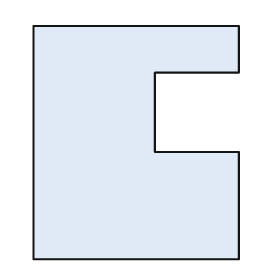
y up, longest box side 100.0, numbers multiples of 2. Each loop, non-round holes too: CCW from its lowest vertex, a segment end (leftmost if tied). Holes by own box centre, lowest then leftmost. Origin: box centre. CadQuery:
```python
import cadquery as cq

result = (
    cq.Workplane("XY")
    .moveTo(-44.0, -50.0)
    .lineTo(44.0, -50.0)
    .lineTo(44.0, -4.0)
    .lineTo(8.0, -4.0)
    .lineTo(8.0, 30.0)
    .lineTo(44.0, 30.0)
    .lineTo(44.0, 50.0)
    .lineTo(-44.0, 50.0)
    .close()
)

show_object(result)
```